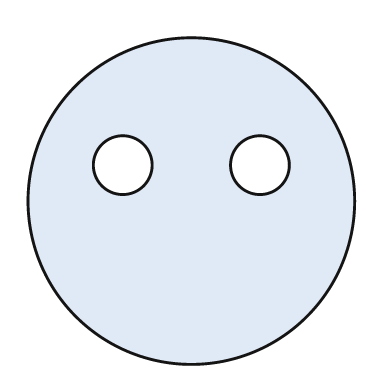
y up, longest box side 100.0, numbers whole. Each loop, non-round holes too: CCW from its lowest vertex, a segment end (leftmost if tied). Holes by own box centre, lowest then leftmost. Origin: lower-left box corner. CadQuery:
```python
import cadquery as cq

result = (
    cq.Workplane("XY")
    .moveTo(50.0, 50.0)
    .circle(50.0)
    .moveTo(29.0, 61.0)
    .circle(9.0)
    .moveTo(71.0, 61.0)
    .circle(9.0)
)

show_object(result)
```